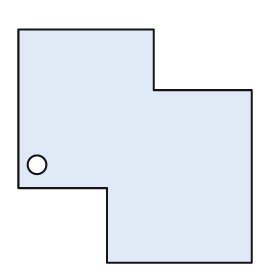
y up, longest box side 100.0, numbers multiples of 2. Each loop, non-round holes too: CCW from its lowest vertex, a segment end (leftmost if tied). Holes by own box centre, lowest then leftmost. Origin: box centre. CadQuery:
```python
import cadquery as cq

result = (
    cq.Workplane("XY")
    .moveTo(-12.0, -50.0)
    .lineTo(50.0, -50.0)
    .lineTo(50.0, 24.0)
    .lineTo(8.0, 24.0)
    .lineTo(8.0, 50.0)
    .lineTo(-50.0, 50.0)
    .lineTo(-50.0, -18.0)
    .lineTo(-12.0, -18.0)
    .close()
    .moveTo(-42.0, -8.0)
    .circle(4.0)
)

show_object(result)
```